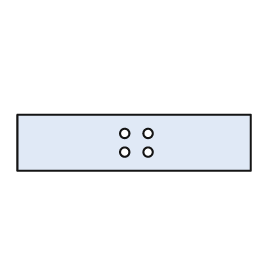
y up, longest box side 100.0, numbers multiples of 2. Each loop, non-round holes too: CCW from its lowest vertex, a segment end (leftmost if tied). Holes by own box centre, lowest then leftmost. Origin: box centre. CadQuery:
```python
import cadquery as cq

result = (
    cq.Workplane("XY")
    .moveTo(-50.0, -12.0)
    .lineTo(50.0, -12.0)
    .lineTo(50.0, 12.0)
    .lineTo(-50.0, 12.0)
    .close()
    .moveTo(-4.0, -4.0)
    .circle(2.0)
    .moveTo(6.0, -4.0)
    .circle(2.0)
    .moveTo(-4.0, 4.0)
    .circle(2.0)
    .moveTo(6.0, 4.0)
    .circle(2.0)
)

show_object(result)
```